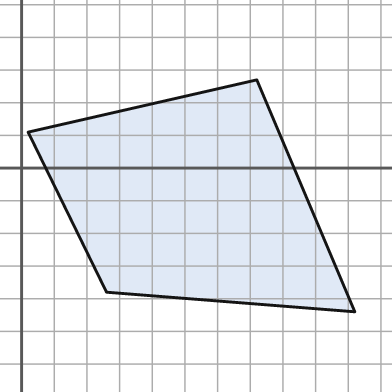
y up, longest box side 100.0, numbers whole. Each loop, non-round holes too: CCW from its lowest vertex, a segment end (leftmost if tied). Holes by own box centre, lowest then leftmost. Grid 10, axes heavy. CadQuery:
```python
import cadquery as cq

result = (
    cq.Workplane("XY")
    .moveTo(102.0, -44.0)
    .lineTo(72.0, 27.0)
    .lineTo(2.0, 11.0)
    .lineTo(26.0, -38.0)
    .close()
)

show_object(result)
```